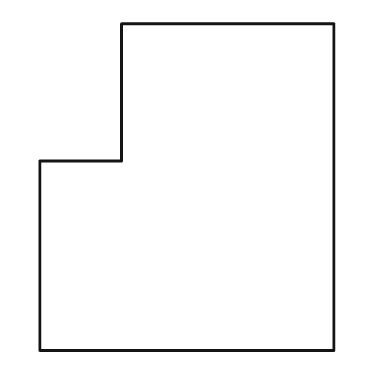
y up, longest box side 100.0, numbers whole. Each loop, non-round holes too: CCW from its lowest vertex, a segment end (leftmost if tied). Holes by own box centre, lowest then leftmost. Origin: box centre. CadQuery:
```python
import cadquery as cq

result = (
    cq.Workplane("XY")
    .moveTo(-45.0, -50.0)
    .lineTo(45.0, -50.0)
    .lineTo(45.0, 50.0)
    .lineTo(-20.0, 50.0)
    .lineTo(-20.0, 8.0)
    .lineTo(-45.0, 8.0)
    .close()
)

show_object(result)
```